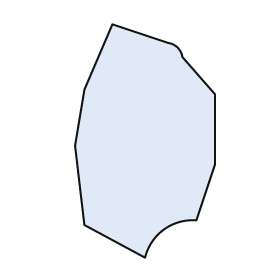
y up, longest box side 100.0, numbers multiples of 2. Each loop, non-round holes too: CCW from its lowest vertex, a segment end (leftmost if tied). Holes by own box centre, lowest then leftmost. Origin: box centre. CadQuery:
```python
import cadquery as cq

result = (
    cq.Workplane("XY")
    .moveTo(0.0, -50.0)
    .threePointArc((8.0, -38.0), (22.0, -34.0))
    .lineTo(30.0, -10.0)
    .lineTo(30.0, 20.0)
    .lineTo(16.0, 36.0)
    .threePointArc((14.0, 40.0), (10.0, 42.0))
    .lineTo(-14.0, 50.0)
    .lineTo(-26.0, 22.0)
    .lineTo(-30.0, -2.0)
    .lineTo(-26.0, -36.0)
    .close()
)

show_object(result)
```